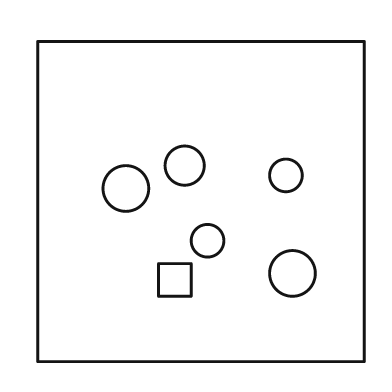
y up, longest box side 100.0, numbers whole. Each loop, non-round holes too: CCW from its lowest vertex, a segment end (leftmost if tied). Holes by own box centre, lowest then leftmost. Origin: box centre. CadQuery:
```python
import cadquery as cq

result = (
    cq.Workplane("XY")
    .moveTo(-50.0, -49.0)
    .lineTo(50.0, -49.0)
    .lineTo(50.0, 49.0)
    .lineTo(-50.0, 49.0)
    .close()
    .moveTo(-13.0, -29.0)
    .lineTo(-3.0, -29.0)
    .lineTo(-3.0, -19.0)
    .lineTo(-13.0, -19.0)
    .close()
    .moveTo(28.0, -22.0)
    .circle(7.0)
    .moveTo(2.0, -12.0)
    .circle(5.0)
    .moveTo(-23.0, 4.0)
    .circle(7.0)
    .moveTo(26.0, 8.0)
    .circle(5.0)
    .moveTo(-5.0, 11.0)
    .circle(6.0)
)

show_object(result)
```